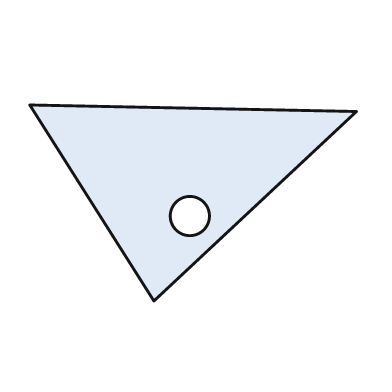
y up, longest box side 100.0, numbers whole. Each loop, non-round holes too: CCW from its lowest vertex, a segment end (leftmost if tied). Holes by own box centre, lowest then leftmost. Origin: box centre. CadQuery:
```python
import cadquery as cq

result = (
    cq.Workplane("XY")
    .moveTo(-12.0, -30.0)
    .lineTo(50.0, 28.0)
    .lineTo(-50.0, 30.0)
    .close()
    .moveTo(-1.0, -4.0)
    .circle(6.0)
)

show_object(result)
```